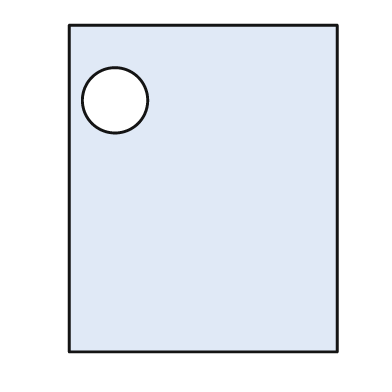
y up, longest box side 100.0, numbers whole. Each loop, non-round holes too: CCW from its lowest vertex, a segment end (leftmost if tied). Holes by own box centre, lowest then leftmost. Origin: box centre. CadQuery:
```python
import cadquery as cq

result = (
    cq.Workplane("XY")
    .moveTo(-41.0, -50.0)
    .lineTo(41.0, -50.0)
    .lineTo(41.0, 50.0)
    .lineTo(-41.0, 50.0)
    .close()
    .moveTo(-27.0, 27.0)
    .circle(10.0)
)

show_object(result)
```